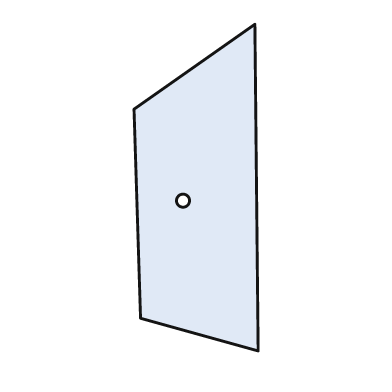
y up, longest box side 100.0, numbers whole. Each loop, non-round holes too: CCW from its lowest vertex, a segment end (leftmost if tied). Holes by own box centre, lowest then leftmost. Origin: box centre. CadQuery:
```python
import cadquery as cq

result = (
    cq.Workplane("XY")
    .moveTo(19.0, -50.0)
    .lineTo(18.0, 50.0)
    .lineTo(-19.0, 24.0)
    .lineTo(-17.0, -40.0)
    .close()
    .moveTo(-4.0, -4.0)
    .circle(2.0)
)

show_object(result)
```